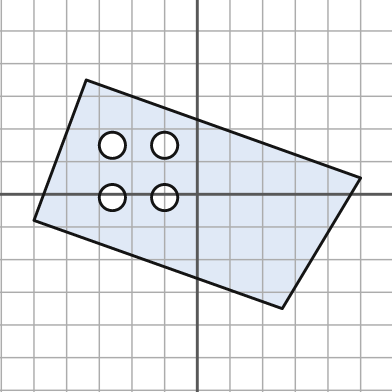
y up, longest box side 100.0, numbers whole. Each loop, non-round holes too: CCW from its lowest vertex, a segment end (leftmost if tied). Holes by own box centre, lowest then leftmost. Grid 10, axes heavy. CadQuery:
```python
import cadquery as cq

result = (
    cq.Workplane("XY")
    .moveTo(26.0, -35.0)
    .lineTo(50.0, 5.0)
    .lineTo(-34.0, 35.0)
    .lineTo(-50.0, -8.0)
    .close()
    .moveTo(-26.0, -1.0)
    .circle(4.0)
    .moveTo(-10.0, -1.0)
    .circle(4.0)
    .moveTo(-26.0, 15.0)
    .circle(4.0)
    .moveTo(-10.0, 15.0)
    .circle(4.0)
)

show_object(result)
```